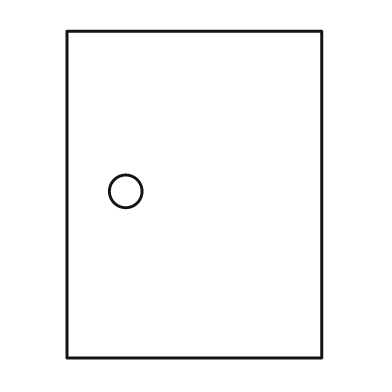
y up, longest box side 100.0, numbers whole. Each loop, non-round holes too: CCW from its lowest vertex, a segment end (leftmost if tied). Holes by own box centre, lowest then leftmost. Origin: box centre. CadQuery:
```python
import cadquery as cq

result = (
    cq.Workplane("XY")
    .moveTo(-39.0, -50.0)
    .lineTo(39.0, -50.0)
    .lineTo(39.0, 50.0)
    .lineTo(-39.0, 50.0)
    .close()
    .moveTo(-21.0, 1.0)
    .circle(5.0)
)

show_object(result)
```